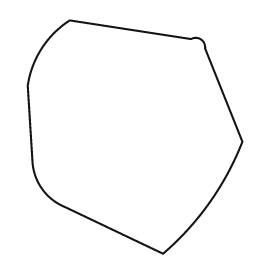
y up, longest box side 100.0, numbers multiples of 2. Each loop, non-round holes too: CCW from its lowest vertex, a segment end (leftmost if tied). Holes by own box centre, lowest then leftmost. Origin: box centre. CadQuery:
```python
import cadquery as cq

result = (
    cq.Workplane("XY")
    .moveTo(12.0, -50.0)
    .threePointArc((32.0, -28.0), (46.0, -2.0))
    .lineTo(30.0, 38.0)
    .threePointArc((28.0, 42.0), (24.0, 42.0))
    .lineTo(-28.0, 50.0)
    .threePointArc((-40.0, 38.0), (-46.0, 22.0))
    .lineTo(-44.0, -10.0)
    .threePointArc((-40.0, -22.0), (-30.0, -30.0))
    .close()
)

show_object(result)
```